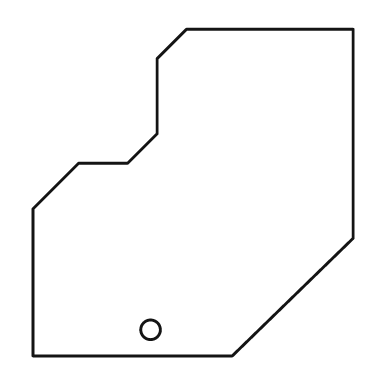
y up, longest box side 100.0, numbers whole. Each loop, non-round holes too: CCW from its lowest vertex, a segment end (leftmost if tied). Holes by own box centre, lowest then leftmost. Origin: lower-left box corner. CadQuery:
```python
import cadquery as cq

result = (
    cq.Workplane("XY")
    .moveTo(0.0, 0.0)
    .lineTo(61.0, 0.0)
    .lineTo(98.0, 36.0)
    .lineTo(98.0, 100.0)
    .lineTo(47.0, 100.0)
    .lineTo(38.0, 91.0)
    .lineTo(38.0, 68.0)
    .lineTo(29.0, 59.0)
    .lineTo(14.0, 59.0)
    .lineTo(0.0, 45.0)
    .close()
    .moveTo(36.0, 8.0)
    .circle(3.0)
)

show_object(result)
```